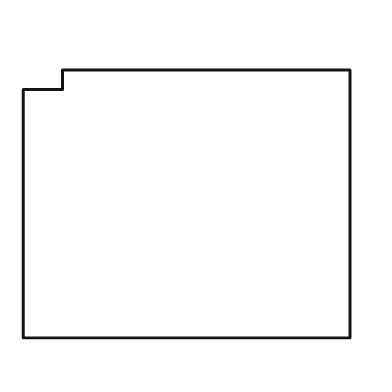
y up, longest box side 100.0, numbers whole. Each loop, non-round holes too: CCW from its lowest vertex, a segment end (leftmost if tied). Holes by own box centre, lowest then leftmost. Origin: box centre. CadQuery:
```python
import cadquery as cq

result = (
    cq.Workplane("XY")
    .moveTo(-50.0, -41.0)
    .lineTo(50.0, -41.0)
    .lineTo(50.0, 41.0)
    .lineTo(-38.0, 41.0)
    .lineTo(-38.0, 35.0)
    .lineTo(-50.0, 35.0)
    .close()
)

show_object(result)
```